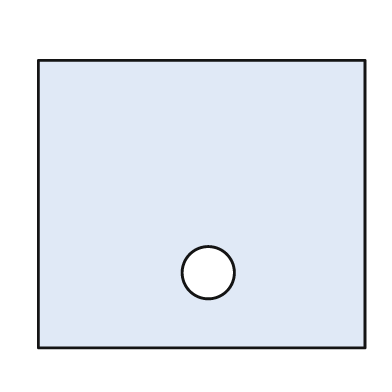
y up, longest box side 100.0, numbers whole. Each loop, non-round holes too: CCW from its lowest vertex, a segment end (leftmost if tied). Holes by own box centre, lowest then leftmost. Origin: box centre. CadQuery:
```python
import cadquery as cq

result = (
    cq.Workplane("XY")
    .moveTo(-50.0, -44.0)
    .lineTo(50.0, -44.0)
    .lineTo(50.0, 44.0)
    .lineTo(-50.0, 44.0)
    .close()
    .moveTo(2.0, -21.0)
    .circle(8.0)
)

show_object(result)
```